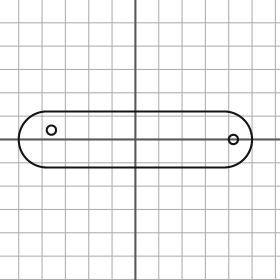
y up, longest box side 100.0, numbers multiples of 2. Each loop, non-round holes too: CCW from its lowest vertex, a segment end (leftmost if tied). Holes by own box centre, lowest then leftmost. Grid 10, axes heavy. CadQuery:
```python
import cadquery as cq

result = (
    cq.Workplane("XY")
    .moveTo(-38.0, -12.0)
    .lineTo(38.0, -12.0)
    .threePointArc((50.0, 0.0), (38.0, 12.0))
    .lineTo(-38.0, 12.0)
    .threePointArc((-50.0, 0.0), (-38.0, -12.0))
    .close()
    .moveTo(42.0, 0.0)
    .circle(2.0)
    .moveTo(-36.0, 4.0)
    .circle(2.0)
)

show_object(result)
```